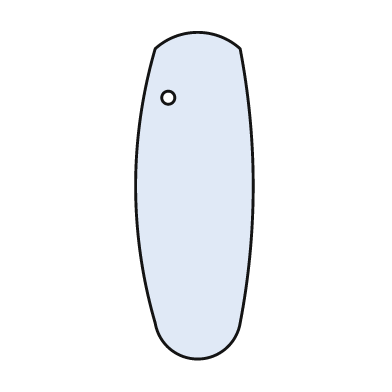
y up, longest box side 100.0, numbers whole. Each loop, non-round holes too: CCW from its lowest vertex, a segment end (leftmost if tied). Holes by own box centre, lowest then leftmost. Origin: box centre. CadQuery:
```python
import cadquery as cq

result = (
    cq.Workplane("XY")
    .moveTo(-12.0, -39.0)
    .threePointArc((1.0, -50.0), (14.0, -39.0))
    .threePointArc((18.0, 3.0), (14.0, 45.0))
    .threePointArc((1.0, 50.0), (-12.0, 45.0))
    .threePointArc((-18.0, 3.0), (-12.0, -39.0))
    .close()
    .moveTo(-8.0, 30.0)
    .circle(2.0)
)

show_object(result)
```